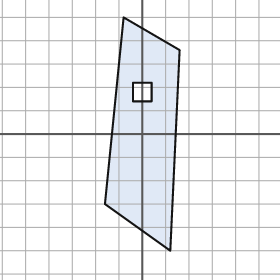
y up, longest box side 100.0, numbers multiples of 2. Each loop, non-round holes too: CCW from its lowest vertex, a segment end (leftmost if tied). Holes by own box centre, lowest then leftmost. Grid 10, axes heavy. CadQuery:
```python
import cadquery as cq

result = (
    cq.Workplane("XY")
    .moveTo(12.0, -50.0)
    .lineTo(16.0, 36.0)
    .lineTo(-8.0, 50.0)
    .lineTo(-16.0, -30.0)
    .close()
    .moveTo(-4.0, 14.0)
    .lineTo(4.0, 14.0)
    .lineTo(4.0, 22.0)
    .lineTo(-4.0, 22.0)
    .close()
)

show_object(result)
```